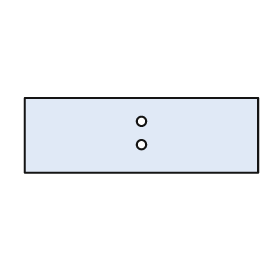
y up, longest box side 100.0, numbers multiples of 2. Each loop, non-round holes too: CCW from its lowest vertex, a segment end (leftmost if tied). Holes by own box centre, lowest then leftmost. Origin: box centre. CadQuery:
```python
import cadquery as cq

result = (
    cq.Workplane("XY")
    .moveTo(-50.0, -16.0)
    .lineTo(50.0, -16.0)
    .lineTo(50.0, 16.0)
    .lineTo(-50.0, 16.0)
    .close()
    .moveTo(0.0, -4.0)
    .circle(2.0)
    .moveTo(0.0, 6.0)
    .circle(2.0)
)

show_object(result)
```